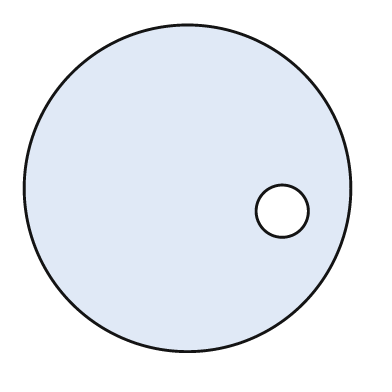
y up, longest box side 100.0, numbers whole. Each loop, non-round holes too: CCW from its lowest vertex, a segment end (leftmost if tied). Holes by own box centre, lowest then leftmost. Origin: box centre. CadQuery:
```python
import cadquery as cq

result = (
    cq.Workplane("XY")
    .moveTo(0.0, 0.0)
    .circle(50.0)
    .moveTo(29.0, -7.0)
    .circle(8.0)
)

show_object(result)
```